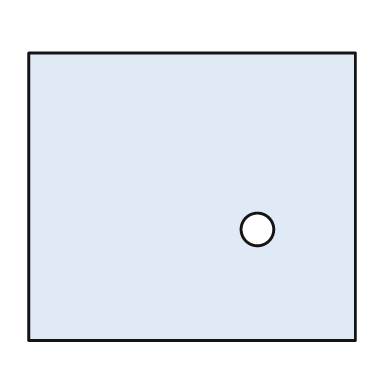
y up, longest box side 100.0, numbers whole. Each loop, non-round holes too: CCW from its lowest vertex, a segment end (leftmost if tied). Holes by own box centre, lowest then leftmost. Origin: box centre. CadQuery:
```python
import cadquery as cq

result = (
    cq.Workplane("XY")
    .moveTo(-50.0, -44.0)
    .lineTo(50.0, -44.0)
    .lineTo(50.0, 44.0)
    .lineTo(-50.0, 44.0)
    .close()
    .moveTo(20.0, -10.0)
    .circle(5.0)
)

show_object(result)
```